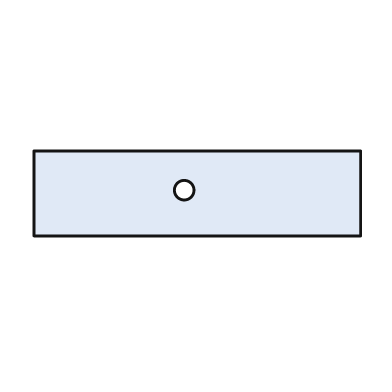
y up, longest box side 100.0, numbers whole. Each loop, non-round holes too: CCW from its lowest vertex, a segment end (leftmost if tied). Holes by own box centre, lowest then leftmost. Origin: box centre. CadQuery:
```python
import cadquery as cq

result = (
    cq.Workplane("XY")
    .moveTo(-50.0, -13.0)
    .lineTo(50.0, -13.0)
    .lineTo(50.0, 13.0)
    .lineTo(-50.0, 13.0)
    .close()
    .moveTo(-4.0, 1.0)
    .circle(3.0)
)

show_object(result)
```